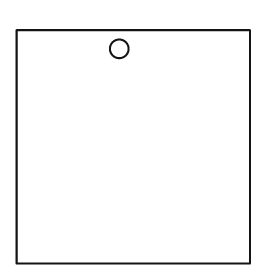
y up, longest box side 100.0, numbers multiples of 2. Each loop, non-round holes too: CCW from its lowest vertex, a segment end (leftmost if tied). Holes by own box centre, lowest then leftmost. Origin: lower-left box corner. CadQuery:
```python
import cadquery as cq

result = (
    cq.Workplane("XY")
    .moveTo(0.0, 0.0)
    .lineTo(100.0, 0.0)
    .lineTo(100.0, 100.0)
    .lineTo(0.0, 100.0)
    .close()
    .moveTo(44.0, 92.0)
    .circle(4.0)
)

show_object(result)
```